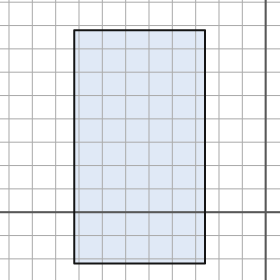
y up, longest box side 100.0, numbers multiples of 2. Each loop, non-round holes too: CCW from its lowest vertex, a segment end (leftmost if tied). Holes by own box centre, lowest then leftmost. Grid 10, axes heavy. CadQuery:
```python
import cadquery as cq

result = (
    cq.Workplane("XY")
    .moveTo(-82.0, -22.0)
    .lineTo(-26.0, -22.0)
    .lineTo(-26.0, 78.0)
    .lineTo(-82.0, 78.0)
    .close()
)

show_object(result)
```